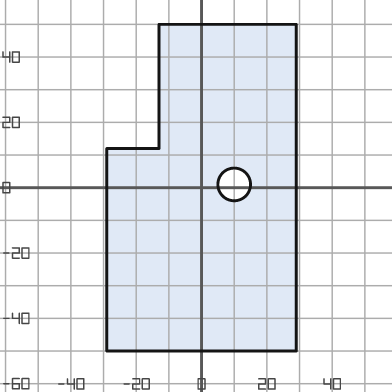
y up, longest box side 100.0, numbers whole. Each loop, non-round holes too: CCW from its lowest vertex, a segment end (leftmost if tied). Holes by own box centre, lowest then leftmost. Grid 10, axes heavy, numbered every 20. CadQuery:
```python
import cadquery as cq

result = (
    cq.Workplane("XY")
    .moveTo(-29.0, -50.0)
    .lineTo(29.0, -50.0)
    .lineTo(29.0, 50.0)
    .lineTo(-13.0, 50.0)
    .lineTo(-13.0, 12.0)
    .lineTo(-29.0, 12.0)
    .close()
    .moveTo(10.0, 1.0)
    .circle(5.0)
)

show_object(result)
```